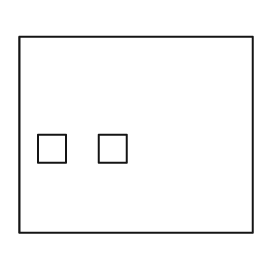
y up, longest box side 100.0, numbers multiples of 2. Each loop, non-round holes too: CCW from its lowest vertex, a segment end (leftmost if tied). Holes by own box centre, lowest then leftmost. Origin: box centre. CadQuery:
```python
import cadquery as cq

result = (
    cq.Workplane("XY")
    .moveTo(-50.0, -42.0)
    .lineTo(50.0, -42.0)
    .lineTo(50.0, 42.0)
    .lineTo(-50.0, 42.0)
    .close()
    .moveTo(-42.0, -12.0)
    .lineTo(-30.0, -12.0)
    .lineTo(-30.0, 0.0)
    .lineTo(-42.0, 0.0)
    .close()
    .moveTo(-16.0, -12.0)
    .lineTo(-4.0, -12.0)
    .lineTo(-4.0, 0.0)
    .lineTo(-16.0, 0.0)
    .close()
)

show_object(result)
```